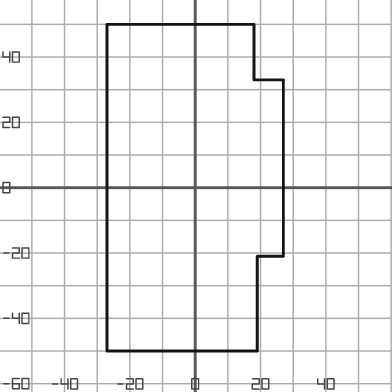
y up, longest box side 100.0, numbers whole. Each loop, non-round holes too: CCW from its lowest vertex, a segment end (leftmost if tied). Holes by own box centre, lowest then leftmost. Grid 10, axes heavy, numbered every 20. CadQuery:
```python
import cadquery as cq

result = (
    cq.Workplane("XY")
    .moveTo(-27.0, -50.0)
    .lineTo(19.0, -50.0)
    .lineTo(19.0, -21.0)
    .lineTo(27.0, -21.0)
    .lineTo(27.0, 33.0)
    .lineTo(18.0, 33.0)
    .lineTo(18.0, 50.0)
    .lineTo(-27.0, 50.0)
    .close()
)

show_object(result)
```